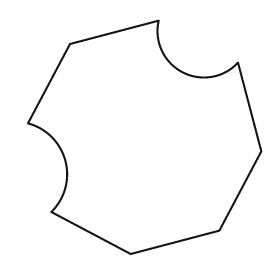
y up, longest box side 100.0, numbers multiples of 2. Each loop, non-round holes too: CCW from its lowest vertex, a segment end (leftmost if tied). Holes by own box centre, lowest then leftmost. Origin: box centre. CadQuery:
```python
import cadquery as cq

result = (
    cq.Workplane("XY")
    .moveTo(-6.0, -50.0)
    .lineTo(32.0, -40.0)
    .lineTo(50.0, -6.0)
    .lineTo(40.0, 32.0)
    .threePointArc((16.0, 28.0), (6.0, 50.0))
    .lineTo(-32.0, 40.0)
    .lineTo(-50.0, 6.0)
    .threePointArc((-34.0, -10.0), (-40.0, -32.0))
    .close()
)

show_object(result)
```